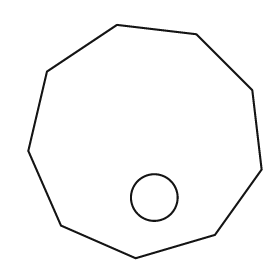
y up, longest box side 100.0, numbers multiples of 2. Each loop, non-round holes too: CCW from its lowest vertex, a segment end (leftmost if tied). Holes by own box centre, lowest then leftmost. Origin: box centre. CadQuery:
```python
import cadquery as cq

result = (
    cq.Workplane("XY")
    .moveTo(-4.0, -50.0)
    .lineTo(30.0, -40.0)
    .lineTo(50.0, -12.0)
    .lineTo(46.0, 22.0)
    .lineTo(22.0, 46.0)
    .lineTo(-12.0, 50.0)
    .lineTo(-42.0, 30.0)
    .lineTo(-50.0, -4.0)
    .lineTo(-36.0, -36.0)
    .close()
    .moveTo(4.0, -24.0)
    .circle(10.0)
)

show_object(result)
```